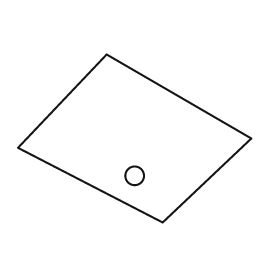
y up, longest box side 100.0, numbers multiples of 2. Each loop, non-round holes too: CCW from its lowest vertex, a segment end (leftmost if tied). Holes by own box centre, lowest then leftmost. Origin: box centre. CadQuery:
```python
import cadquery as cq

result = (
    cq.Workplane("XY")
    .moveTo(12.0, -36.0)
    .lineTo(50.0, 0.0)
    .lineTo(-12.0, 36.0)
    .lineTo(-50.0, -4.0)
    .close()
    .moveTo(0.0, -16.0)
    .circle(4.0)
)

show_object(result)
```